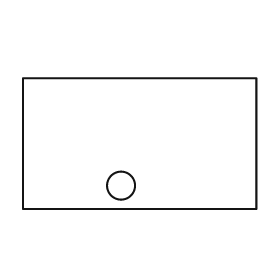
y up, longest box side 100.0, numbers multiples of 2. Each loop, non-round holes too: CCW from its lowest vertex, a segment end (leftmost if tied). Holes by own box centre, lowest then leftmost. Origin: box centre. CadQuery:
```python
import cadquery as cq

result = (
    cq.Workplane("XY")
    .moveTo(-50.0, -28.0)
    .lineTo(50.0, -28.0)
    .lineTo(50.0, 28.0)
    .lineTo(-50.0, 28.0)
    .close()
    .moveTo(-8.0, -18.0)
    .circle(6.0)
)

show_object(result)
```